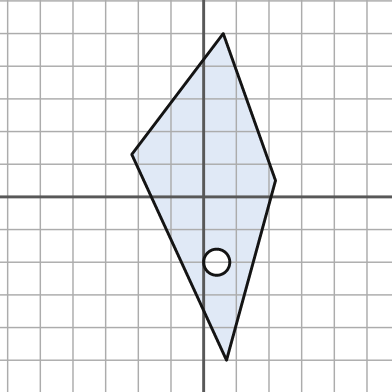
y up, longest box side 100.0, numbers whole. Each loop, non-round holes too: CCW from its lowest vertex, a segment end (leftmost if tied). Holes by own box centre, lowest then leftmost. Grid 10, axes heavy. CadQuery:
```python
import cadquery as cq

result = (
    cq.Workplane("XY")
    .moveTo(7.0, -50.0)
    .lineTo(22.0, 5.0)
    .lineTo(6.0, 50.0)
    .lineTo(-22.0, 13.0)
    .close()
    .moveTo(4.0, -20.0)
    .circle(4.0)
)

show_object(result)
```